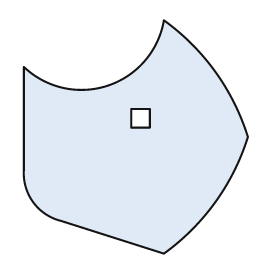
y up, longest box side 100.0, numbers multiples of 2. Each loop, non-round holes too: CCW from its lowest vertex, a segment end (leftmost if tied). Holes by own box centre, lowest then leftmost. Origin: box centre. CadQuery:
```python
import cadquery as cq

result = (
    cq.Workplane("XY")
    .moveTo(12.0, -50.0)
    .threePointArc((34.0, -28.0), (48.0, 0.0))
    .threePointArc((34.0, 28.0), (12.0, 50.0))
    .threePointArc((-12.0, 22.0), (-48.0, 30.0))
    .lineTo(-48.0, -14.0)
    .threePointArc((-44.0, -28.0), (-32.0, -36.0))
    .close()
    .moveTo(-2.0, 4.0)
    .lineTo(6.0, 4.0)
    .lineTo(6.0, 12.0)
    .lineTo(-2.0, 12.0)
    .close()
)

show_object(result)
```